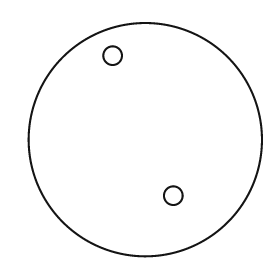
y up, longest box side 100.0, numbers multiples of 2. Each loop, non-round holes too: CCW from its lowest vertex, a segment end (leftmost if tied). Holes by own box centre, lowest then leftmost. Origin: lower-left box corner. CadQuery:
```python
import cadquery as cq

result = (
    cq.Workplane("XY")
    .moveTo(50.0, 50.0)
    .circle(50.0)
    .moveTo(62.0, 26.0)
    .circle(4.0)
    .moveTo(36.0, 86.0)
    .circle(4.0)
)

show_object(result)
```